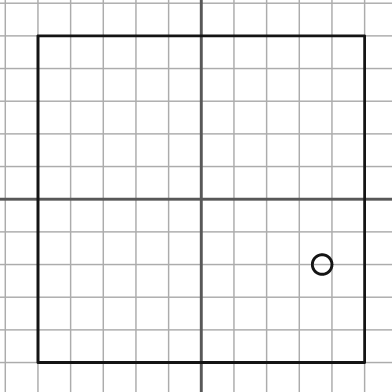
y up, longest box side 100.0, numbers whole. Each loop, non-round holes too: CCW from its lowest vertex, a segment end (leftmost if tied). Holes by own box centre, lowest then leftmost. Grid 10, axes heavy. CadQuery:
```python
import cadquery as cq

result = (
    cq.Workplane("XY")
    .moveTo(-50.0, -50.0)
    .lineTo(50.0, -50.0)
    .lineTo(50.0, 50.0)
    .lineTo(-50.0, 50.0)
    .close()
    .moveTo(37.0, -20.0)
    .circle(3.0)
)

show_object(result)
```